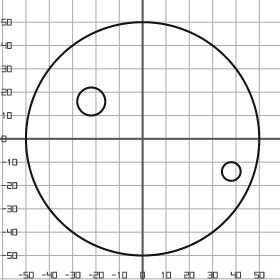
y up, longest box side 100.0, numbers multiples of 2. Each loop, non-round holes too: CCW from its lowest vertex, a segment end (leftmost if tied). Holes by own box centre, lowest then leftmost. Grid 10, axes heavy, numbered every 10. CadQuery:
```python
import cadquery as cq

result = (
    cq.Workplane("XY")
    .moveTo(0.0, 0.0)
    .circle(50.0)
    .moveTo(38.0, -14.0)
    .circle(4.0)
    .moveTo(-22.0, 16.0)
    .circle(6.0)
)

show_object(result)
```